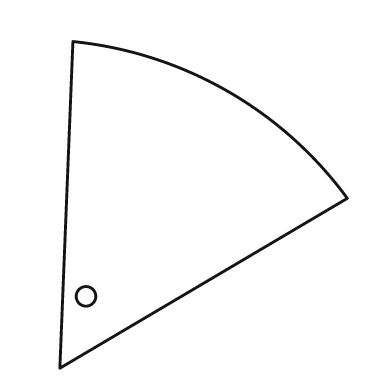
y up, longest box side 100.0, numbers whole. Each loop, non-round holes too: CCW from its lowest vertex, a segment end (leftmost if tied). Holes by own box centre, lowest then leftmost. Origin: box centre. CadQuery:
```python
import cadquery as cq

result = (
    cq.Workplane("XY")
    .moveTo(-44.0, -50.0)
    .lineTo(44.0, 2.0)
    .threePointArc((7.0, 35.0), (-40.0, 50.0))
    .close()
    .moveTo(-36.0, -28.0)
    .circle(3.0)
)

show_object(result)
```